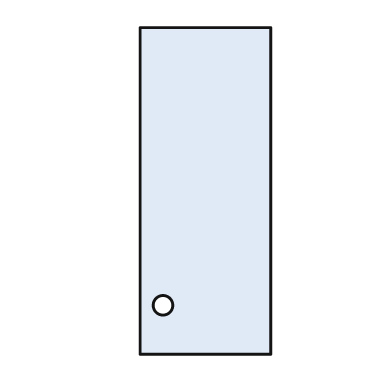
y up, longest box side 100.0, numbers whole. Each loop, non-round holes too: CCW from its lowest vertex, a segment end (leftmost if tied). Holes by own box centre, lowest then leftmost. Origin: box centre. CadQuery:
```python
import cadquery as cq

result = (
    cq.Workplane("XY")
    .moveTo(-20.0, -50.0)
    .lineTo(20.0, -50.0)
    .lineTo(20.0, 50.0)
    .lineTo(-20.0, 50.0)
    .close()
    .moveTo(-13.0, -35.0)
    .circle(3.0)
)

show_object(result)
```